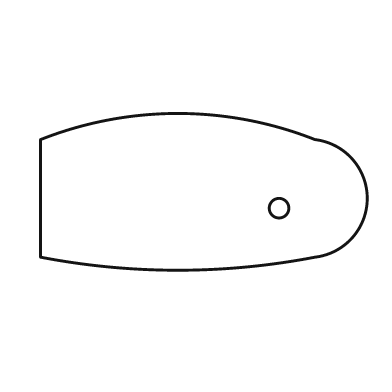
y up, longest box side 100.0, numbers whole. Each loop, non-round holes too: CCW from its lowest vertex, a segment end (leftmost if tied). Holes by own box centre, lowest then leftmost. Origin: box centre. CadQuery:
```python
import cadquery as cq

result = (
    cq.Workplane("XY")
    .moveTo(-50.0, -20.0)
    .threePointArc((-8.0, -24.0), (34.0, -20.0))
    .threePointArc((50.0, -2.0), (34.0, 16.0))
    .threePointArc((-8.0, 24.0), (-50.0, 16.0))
    .close()
    .moveTo(23.0, -5.0)
    .circle(3.0)
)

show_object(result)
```